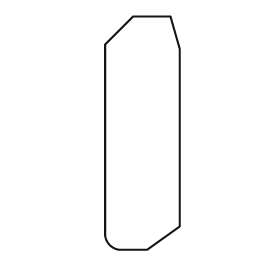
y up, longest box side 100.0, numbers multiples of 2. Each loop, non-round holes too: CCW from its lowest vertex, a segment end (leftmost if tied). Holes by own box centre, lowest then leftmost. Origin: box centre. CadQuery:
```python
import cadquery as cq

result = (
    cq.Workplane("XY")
    .moveTo(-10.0, -50.0)
    .lineTo(2.0, -50.0)
    .lineTo(16.0, -40.0)
    .lineTo(16.0, 36.0)
    .lineTo(12.0, 50.0)
    .lineTo(-4.0, 50.0)
    .lineTo(-16.0, 38.0)
    .lineTo(-16.0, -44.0)
    .threePointArc((-14.0, -48.0), (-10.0, -50.0))
    .close()
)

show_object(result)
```